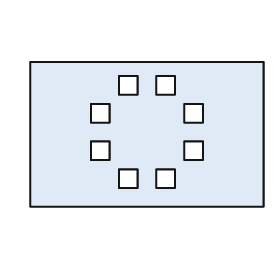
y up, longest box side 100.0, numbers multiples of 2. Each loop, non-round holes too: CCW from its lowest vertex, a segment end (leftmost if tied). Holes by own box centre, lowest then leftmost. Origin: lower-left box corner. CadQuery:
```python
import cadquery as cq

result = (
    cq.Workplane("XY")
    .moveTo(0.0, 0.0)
    .lineTo(100.0, 0.0)
    .lineTo(100.0, 62.0)
    .lineTo(0.0, 62.0)
    .close()
    .moveTo(38.0, 8.0)
    .lineTo(46.0, 8.0)
    .lineTo(46.0, 16.0)
    .lineTo(38.0, 16.0)
    .close()
    .moveTo(54.0, 8.0)
    .lineTo(62.0, 8.0)
    .lineTo(62.0, 16.0)
    .lineTo(54.0, 16.0)
    .close()
    .moveTo(26.0, 20.0)
    .lineTo(34.0, 20.0)
    .lineTo(34.0, 28.0)
    .lineTo(26.0, 28.0)
    .close()
    .moveTo(66.0, 20.0)
    .lineTo(74.0, 20.0)
    .lineTo(74.0, 28.0)
    .lineTo(66.0, 28.0)
    .close()
    .moveTo(26.0, 36.0)
    .lineTo(34.0, 36.0)
    .lineTo(34.0, 44.0)
    .lineTo(26.0, 44.0)
    .close()
    .moveTo(66.0, 36.0)
    .lineTo(74.0, 36.0)
    .lineTo(74.0, 44.0)
    .lineTo(66.0, 44.0)
    .close()
    .moveTo(38.0, 48.0)
    .lineTo(46.0, 48.0)
    .lineTo(46.0, 56.0)
    .lineTo(38.0, 56.0)
    .close()
    .moveTo(54.0, 48.0)
    .lineTo(62.0, 48.0)
    .lineTo(62.0, 56.0)
    .lineTo(54.0, 56.0)
    .close()
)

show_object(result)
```